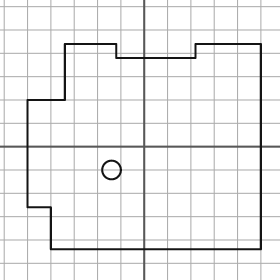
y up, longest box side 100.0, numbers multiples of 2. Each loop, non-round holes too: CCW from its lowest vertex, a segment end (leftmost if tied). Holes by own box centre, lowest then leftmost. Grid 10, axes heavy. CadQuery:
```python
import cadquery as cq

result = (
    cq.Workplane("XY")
    .moveTo(-40.0, -44.0)
    .lineTo(50.0, -44.0)
    .lineTo(50.0, 44.0)
    .lineTo(22.0, 44.0)
    .lineTo(22.0, 38.0)
    .lineTo(-12.0, 38.0)
    .lineTo(-12.0, 44.0)
    .lineTo(-34.0, 44.0)
    .lineTo(-34.0, 20.0)
    .lineTo(-50.0, 20.0)
    .lineTo(-50.0, -26.0)
    .lineTo(-40.0, -26.0)
    .close()
    .moveTo(-14.0, -10.0)
    .circle(4.0)
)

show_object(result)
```